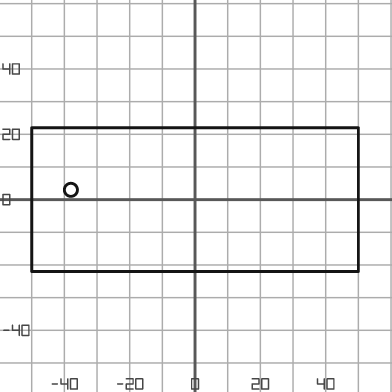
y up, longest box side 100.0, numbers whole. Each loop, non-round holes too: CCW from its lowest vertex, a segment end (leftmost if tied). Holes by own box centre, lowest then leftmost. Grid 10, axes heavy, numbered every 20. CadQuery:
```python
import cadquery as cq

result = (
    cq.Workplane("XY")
    .moveTo(-50.0, -22.0)
    .lineTo(50.0, -22.0)
    .lineTo(50.0, 22.0)
    .lineTo(-50.0, 22.0)
    .close()
    .moveTo(-38.0, 3.0)
    .circle(2.0)
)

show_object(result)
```